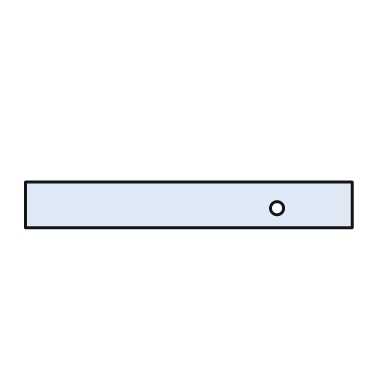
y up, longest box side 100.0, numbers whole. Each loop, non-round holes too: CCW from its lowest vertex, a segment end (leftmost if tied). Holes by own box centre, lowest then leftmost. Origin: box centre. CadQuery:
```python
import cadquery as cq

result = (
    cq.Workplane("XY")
    .moveTo(-50.0, -7.0)
    .lineTo(50.0, -7.0)
    .lineTo(50.0, 7.0)
    .lineTo(-50.0, 7.0)
    .close()
    .moveTo(27.0, -1.0)
    .circle(2.0)
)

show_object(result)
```